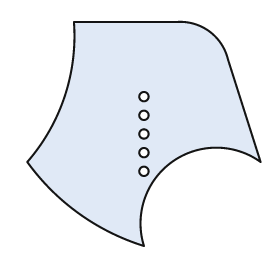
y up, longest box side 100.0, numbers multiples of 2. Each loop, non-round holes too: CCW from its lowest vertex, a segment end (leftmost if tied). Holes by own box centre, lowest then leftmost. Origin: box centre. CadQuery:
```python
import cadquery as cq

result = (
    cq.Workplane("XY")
    .moveTo(0.0, -48.0)
    .threePointArc((12.0, -12.0), (50.0, -12.0))
    .lineTo(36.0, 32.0)
    .threePointArc((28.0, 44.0), (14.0, 48.0))
    .lineTo(-30.0, 48.0)
    .threePointArc((-34.0, 16.0), (-50.0, -12.0))
    .threePointArc((-28.0, -34.0), (0.0, -48.0))
    .close()
    .moveTo(0.0, -16.0)
    .circle(2.0)
    .moveTo(0.0, -8.0)
    .circle(2.0)
    .moveTo(0.0, 0.0)
    .circle(2.0)
    .moveTo(0.0, 8.0)
    .circle(2.0)
    .moveTo(0.0, 16.0)
    .circle(2.0)
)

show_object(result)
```